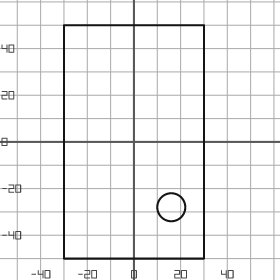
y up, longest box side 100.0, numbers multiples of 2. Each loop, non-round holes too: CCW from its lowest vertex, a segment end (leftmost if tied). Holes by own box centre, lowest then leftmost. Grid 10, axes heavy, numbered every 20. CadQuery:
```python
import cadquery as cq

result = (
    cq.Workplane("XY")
    .moveTo(-30.0, -50.0)
    .lineTo(30.0, -50.0)
    .lineTo(30.0, 50.0)
    .lineTo(-30.0, 50.0)
    .close()
    .moveTo(16.0, -28.0)
    .circle(6.0)
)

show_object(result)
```